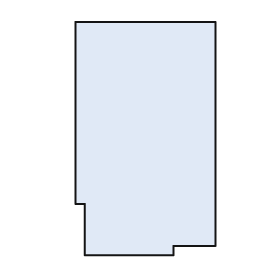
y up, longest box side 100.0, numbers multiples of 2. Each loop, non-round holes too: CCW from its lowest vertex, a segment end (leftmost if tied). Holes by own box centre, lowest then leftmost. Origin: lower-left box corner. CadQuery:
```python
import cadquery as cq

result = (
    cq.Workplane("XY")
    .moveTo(4.0, 0.0)
    .lineTo(42.0, 0.0)
    .lineTo(42.0, 4.0)
    .lineTo(60.0, 4.0)
    .lineTo(60.0, 100.0)
    .lineTo(0.0, 100.0)
    .lineTo(0.0, 22.0)
    .lineTo(4.0, 22.0)
    .close()
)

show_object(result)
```